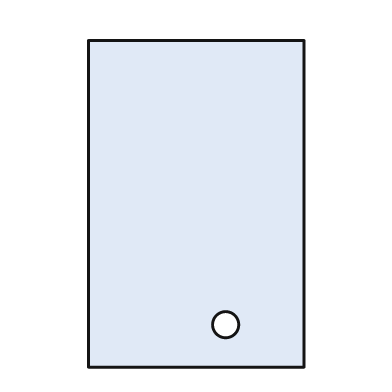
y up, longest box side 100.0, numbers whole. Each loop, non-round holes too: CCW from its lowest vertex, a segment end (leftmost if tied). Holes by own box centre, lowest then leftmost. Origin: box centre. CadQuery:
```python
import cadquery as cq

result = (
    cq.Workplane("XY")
    .moveTo(-33.0, -50.0)
    .lineTo(33.0, -50.0)
    .lineTo(33.0, 50.0)
    .lineTo(-33.0, 50.0)
    .close()
    .moveTo(9.0, -37.0)
    .circle(4.0)
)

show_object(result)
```